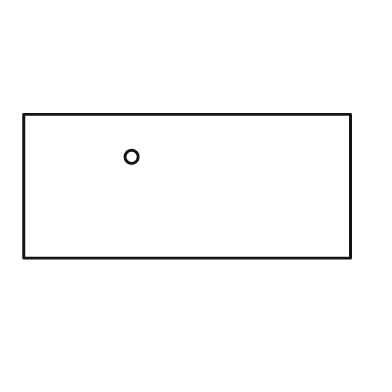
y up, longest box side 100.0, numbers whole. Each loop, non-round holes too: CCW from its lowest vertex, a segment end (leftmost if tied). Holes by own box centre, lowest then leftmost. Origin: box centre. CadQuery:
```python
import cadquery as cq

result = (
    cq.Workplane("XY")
    .moveTo(-50.0, -22.0)
    .lineTo(50.0, -22.0)
    .lineTo(50.0, 22.0)
    .lineTo(-50.0, 22.0)
    .close()
    .moveTo(-17.0, 9.0)
    .circle(2.0)
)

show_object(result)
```